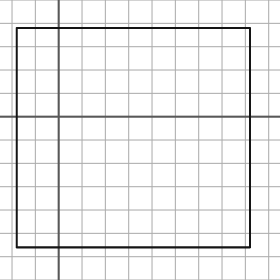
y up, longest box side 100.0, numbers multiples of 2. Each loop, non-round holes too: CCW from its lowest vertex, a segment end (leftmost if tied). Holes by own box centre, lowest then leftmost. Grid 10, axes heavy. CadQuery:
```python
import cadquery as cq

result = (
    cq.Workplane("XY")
    .moveTo(-18.0, -56.0)
    .lineTo(82.0, -56.0)
    .lineTo(82.0, 38.0)
    .lineTo(-18.0, 38.0)
    .close()
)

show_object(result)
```